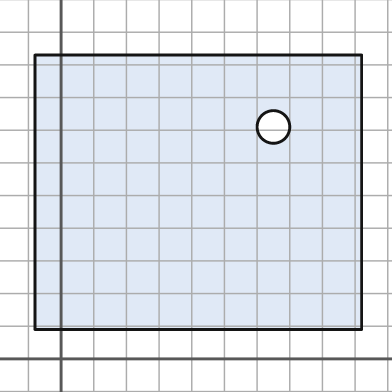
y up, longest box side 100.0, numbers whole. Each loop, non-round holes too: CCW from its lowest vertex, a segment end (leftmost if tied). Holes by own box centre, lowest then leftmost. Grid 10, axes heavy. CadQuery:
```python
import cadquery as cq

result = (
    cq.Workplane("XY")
    .moveTo(-8.0, 9.0)
    .lineTo(92.0, 9.0)
    .lineTo(92.0, 93.0)
    .lineTo(-8.0, 93.0)
    .close()
    .moveTo(65.0, 71.0)
    .circle(5.0)
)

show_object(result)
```